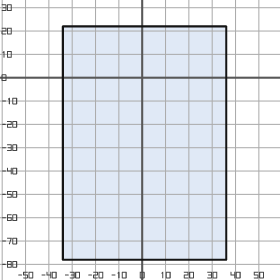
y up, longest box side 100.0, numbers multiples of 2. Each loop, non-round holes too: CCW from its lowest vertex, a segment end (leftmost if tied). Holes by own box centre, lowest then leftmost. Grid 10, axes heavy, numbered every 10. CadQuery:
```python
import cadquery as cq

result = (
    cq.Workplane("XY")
    .moveTo(-34.0, -78.0)
    .lineTo(36.0, -78.0)
    .lineTo(36.0, 22.0)
    .lineTo(-34.0, 22.0)
    .close()
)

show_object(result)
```